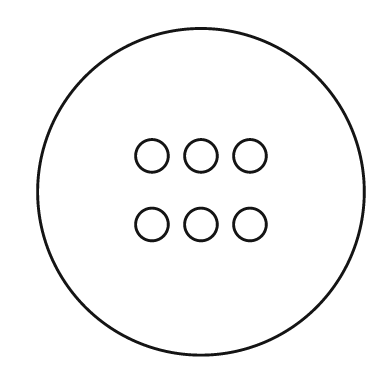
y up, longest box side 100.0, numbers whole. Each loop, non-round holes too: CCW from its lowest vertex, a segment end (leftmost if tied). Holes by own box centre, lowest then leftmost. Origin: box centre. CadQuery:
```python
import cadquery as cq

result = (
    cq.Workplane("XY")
    .moveTo(0.0, 0.0)
    .circle(50.0)
    .moveTo(-15.0, -10.0)
    .circle(5.0)
    .moveTo(0.0, -10.0)
    .circle(5.0)
    .moveTo(15.0, -10.0)
    .circle(5.0)
    .moveTo(-15.0, 11.0)
    .circle(5.0)
    .moveTo(0.0, 11.0)
    .circle(5.0)
    .moveTo(15.0, 11.0)
    .circle(5.0)
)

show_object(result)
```